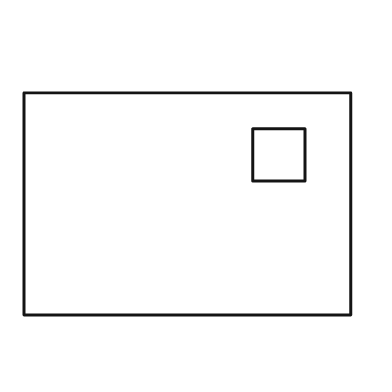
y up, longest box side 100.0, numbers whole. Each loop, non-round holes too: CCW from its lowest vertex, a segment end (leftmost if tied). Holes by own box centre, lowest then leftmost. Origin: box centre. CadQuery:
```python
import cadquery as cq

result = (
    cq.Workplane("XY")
    .moveTo(-50.0, -34.0)
    .lineTo(50.0, -34.0)
    .lineTo(50.0, 34.0)
    .lineTo(-50.0, 34.0)
    .close()
    .moveTo(20.0, 7.0)
    .lineTo(36.0, 7.0)
    .lineTo(36.0, 23.0)
    .lineTo(20.0, 23.0)
    .close()
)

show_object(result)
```